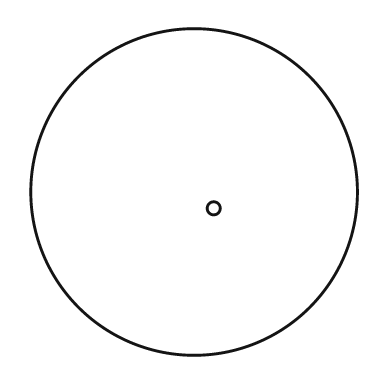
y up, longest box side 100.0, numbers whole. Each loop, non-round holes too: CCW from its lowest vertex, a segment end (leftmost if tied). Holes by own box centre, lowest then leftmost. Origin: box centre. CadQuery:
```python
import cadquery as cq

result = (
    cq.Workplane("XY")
    .moveTo(0.0, 0.0)
    .circle(50.0)
    .moveTo(6.0, -5.0)
    .circle(2.0)
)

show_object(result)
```